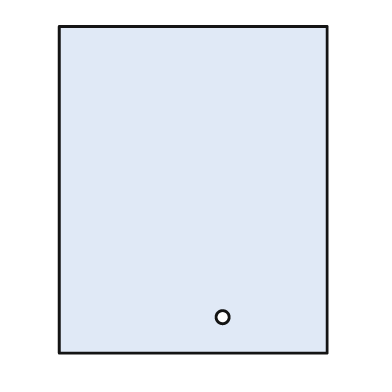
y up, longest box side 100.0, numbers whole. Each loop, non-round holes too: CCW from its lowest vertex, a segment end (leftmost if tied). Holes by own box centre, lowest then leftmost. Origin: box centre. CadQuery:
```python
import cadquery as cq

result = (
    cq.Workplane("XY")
    .moveTo(-41.0, -50.0)
    .lineTo(41.0, -50.0)
    .lineTo(41.0, 50.0)
    .lineTo(-41.0, 50.0)
    .close()
    .moveTo(9.0, -39.0)
    .circle(2.0)
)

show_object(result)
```